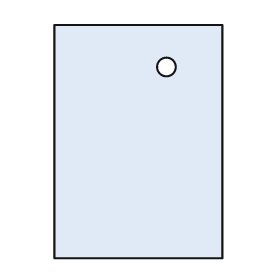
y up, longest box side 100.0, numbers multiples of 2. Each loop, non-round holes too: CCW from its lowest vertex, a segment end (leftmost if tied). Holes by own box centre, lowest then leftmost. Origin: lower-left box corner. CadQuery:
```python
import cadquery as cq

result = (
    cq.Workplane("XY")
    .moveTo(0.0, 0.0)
    .lineTo(72.0, 0.0)
    .lineTo(72.0, 100.0)
    .lineTo(0.0, 100.0)
    .close()
    .moveTo(48.0, 82.0)
    .circle(4.0)
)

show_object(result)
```